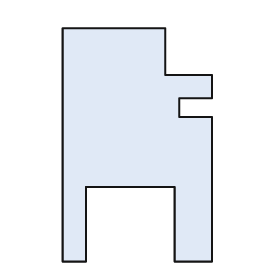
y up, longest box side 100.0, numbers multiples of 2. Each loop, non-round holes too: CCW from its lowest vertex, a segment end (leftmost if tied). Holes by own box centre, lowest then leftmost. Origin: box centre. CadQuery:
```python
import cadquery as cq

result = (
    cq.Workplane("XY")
    .moveTo(-32.0, -50.0)
    .lineTo(-22.0, -50.0)
    .lineTo(-22.0, -18.0)
    .lineTo(16.0, -18.0)
    .lineTo(16.0, -50.0)
    .lineTo(32.0, -50.0)
    .lineTo(32.0, 12.0)
    .lineTo(18.0, 12.0)
    .lineTo(18.0, 20.0)
    .lineTo(32.0, 20.0)
    .lineTo(32.0, 30.0)
    .lineTo(12.0, 30.0)
    .lineTo(12.0, 50.0)
    .lineTo(-32.0, 50.0)
    .close()
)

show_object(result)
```